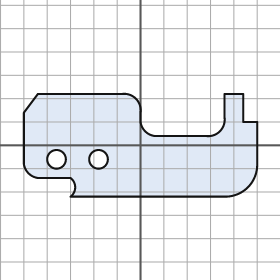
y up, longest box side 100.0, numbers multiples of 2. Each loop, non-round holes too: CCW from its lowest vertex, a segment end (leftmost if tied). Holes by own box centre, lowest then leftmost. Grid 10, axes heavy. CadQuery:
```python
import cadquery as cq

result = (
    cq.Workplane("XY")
    .moveTo(-30.0, -22.0)
    .lineTo(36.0, -22.0)
    .threePointArc((46.0, -18.0), (50.0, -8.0))
    .lineTo(50.0, 10.0)
    .lineTo(44.0, 10.0)
    .lineTo(44.0, 22.0)
    .lineTo(36.0, 22.0)
    .lineTo(36.0, 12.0)
    .threePointArc((34.0, 6.0), (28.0, 4.0))
    .lineTo(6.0, 4.0)
    .threePointArc((2.0, 6.0), (0.0, 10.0))
    .lineTo(0.0, 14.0)
    .threePointArc((-2.0, 20.0), (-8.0, 22.0))
    .lineTo(-44.0, 22.0)
    .lineTo(-50.0, 14.0)
    .lineTo(-50.0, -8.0)
    .threePointArc((-48.0, -12.0), (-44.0, -14.0))
    .lineTo(-30.0, -14.0)
    .threePointArc((-28.0, -18.0), (-30.0, -22.0))
    .close()
    .moveTo(-36.0, -6.0)
    .circle(4.0)
    .moveTo(-18.0, -6.0)
    .circle(4.0)
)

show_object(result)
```